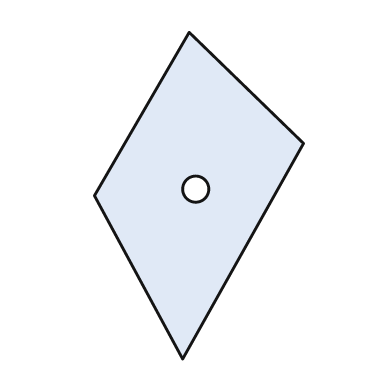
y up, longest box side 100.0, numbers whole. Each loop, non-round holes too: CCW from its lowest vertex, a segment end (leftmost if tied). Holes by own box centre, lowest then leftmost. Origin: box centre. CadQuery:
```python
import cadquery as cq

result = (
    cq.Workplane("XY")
    .moveTo(-5.0, -50.0)
    .lineTo(32.0, 16.0)
    .lineTo(-3.0, 50.0)
    .lineTo(-32.0, 0.0)
    .close()
    .moveTo(-1.0, 2.0)
    .circle(4.0)
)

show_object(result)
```